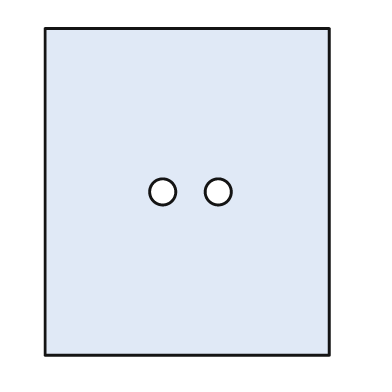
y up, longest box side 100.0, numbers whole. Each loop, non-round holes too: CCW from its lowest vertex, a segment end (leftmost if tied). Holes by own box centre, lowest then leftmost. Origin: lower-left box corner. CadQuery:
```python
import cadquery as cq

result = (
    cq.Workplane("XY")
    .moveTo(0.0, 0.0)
    .lineTo(87.0, 0.0)
    .lineTo(87.0, 100.0)
    .lineTo(0.0, 100.0)
    .close()
    .moveTo(36.0, 50.0)
    .circle(4.0)
    .moveTo(53.0, 50.0)
    .circle(4.0)
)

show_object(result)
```